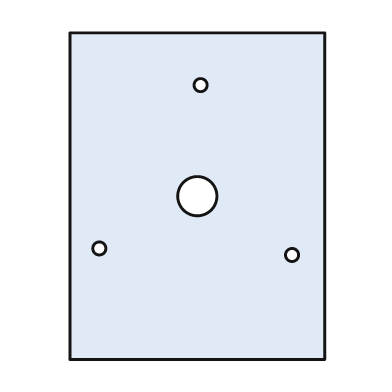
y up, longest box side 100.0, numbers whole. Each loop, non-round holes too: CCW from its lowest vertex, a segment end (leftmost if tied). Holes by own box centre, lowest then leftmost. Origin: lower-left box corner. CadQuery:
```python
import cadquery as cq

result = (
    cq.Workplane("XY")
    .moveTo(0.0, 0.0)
    .lineTo(78.0, 0.0)
    .lineTo(78.0, 100.0)
    .lineTo(0.0, 100.0)
    .close()
    .moveTo(68.0, 32.0)
    .circle(2.0)
    .moveTo(9.0, 34.0)
    .circle(2.0)
    .moveTo(39.0, 50.0)
    .circle(6.0)
    .moveTo(40.0, 84.0)
    .circle(2.0)
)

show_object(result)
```